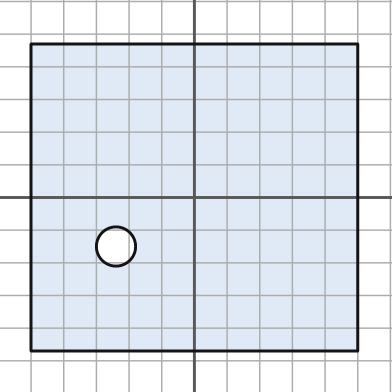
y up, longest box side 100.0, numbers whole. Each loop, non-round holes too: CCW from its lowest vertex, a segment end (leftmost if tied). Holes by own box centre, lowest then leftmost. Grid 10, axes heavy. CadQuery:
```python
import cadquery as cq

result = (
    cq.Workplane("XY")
    .moveTo(-50.0, -47.0)
    .lineTo(50.0, -47.0)
    .lineTo(50.0, 47.0)
    .lineTo(-50.0, 47.0)
    .close()
    .moveTo(-24.0, -15.0)
    .circle(6.0)
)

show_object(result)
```